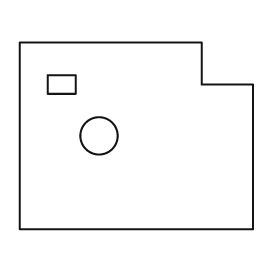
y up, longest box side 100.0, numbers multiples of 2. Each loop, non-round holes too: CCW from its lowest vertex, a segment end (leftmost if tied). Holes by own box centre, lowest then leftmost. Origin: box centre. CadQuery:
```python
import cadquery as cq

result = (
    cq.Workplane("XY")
    .moveTo(-50.0, -40.0)
    .lineTo(50.0, -40.0)
    .lineTo(50.0, 22.0)
    .lineTo(28.0, 22.0)
    .lineTo(28.0, 40.0)
    .lineTo(-50.0, 40.0)
    .close()
    .moveTo(-16.0, 0.0)
    .circle(8.0)
    .moveTo(-38.0, 18.0)
    .lineTo(-26.0, 18.0)
    .lineTo(-26.0, 26.0)
    .lineTo(-38.0, 26.0)
    .close()
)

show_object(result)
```